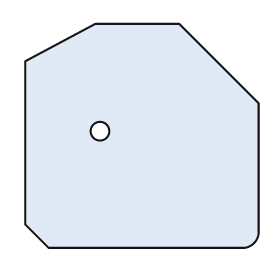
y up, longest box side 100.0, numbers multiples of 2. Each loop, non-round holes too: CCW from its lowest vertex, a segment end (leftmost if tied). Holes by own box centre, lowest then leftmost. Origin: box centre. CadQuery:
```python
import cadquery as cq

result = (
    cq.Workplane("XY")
    .moveTo(-40.0, -48.0)
    .lineTo(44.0, -48.0)
    .threePointArc((48.0, -46.0), (50.0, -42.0))
    .lineTo(50.0, 14.0)
    .lineTo(16.0, 48.0)
    .lineTo(-20.0, 48.0)
    .lineTo(-50.0, 32.0)
    .lineTo(-50.0, -38.0)
    .close()
    .moveTo(-18.0, 2.0)
    .circle(4.0)
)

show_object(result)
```